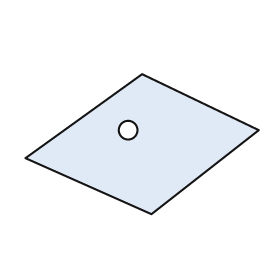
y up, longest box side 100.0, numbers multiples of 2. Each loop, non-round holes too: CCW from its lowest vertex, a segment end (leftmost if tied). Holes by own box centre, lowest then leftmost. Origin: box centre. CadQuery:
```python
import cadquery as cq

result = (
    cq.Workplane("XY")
    .moveTo(4.0, -30.0)
    .lineTo(50.0, 6.0)
    .lineTo(0.0, 30.0)
    .lineTo(-50.0, -6.0)
    .close()
    .moveTo(-6.0, 6.0)
    .circle(4.0)
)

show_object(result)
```